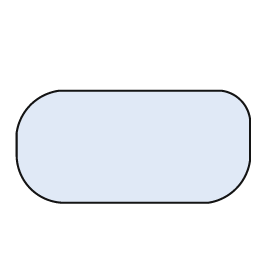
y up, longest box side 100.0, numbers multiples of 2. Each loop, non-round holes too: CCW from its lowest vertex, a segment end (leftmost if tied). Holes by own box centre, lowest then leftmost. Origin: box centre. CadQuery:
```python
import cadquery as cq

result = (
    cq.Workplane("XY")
    .moveTo(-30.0, -24.0)
    .lineTo(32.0, -24.0)
    .threePointArc((44.0, -18.0), (50.0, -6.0))
    .lineTo(50.0, 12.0)
    .threePointArc((46.0, 20.0), (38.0, 24.0))
    .lineTo(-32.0, 24.0)
    .threePointArc((-44.0, 18.0), (-50.0, 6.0))
    .lineTo(-50.0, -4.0)
    .threePointArc((-44.0, -18.0), (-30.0, -24.0))
    .close()
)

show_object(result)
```